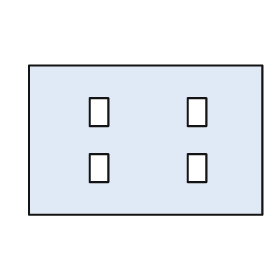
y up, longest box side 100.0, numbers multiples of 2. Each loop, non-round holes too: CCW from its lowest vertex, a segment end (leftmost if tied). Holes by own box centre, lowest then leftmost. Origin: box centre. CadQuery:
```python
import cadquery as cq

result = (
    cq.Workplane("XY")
    .moveTo(-50.0, -32.0)
    .lineTo(50.0, -32.0)
    .lineTo(50.0, 32.0)
    .lineTo(-50.0, 32.0)
    .close()
    .moveTo(-24.0, -18.0)
    .lineTo(-16.0, -18.0)
    .lineTo(-16.0, -6.0)
    .lineTo(-24.0, -6.0)
    .close()
    .moveTo(18.0, -18.0)
    .lineTo(26.0, -18.0)
    .lineTo(26.0, -6.0)
    .lineTo(18.0, -6.0)
    .close()
    .moveTo(-24.0, 6.0)
    .lineTo(-16.0, 6.0)
    .lineTo(-16.0, 18.0)
    .lineTo(-24.0, 18.0)
    .close()
    .moveTo(18.0, 6.0)
    .lineTo(26.0, 6.0)
    .lineTo(26.0, 18.0)
    .lineTo(18.0, 18.0)
    .close()
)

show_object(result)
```